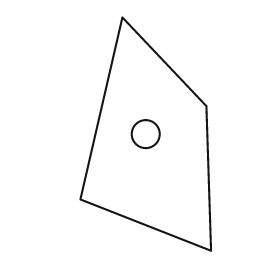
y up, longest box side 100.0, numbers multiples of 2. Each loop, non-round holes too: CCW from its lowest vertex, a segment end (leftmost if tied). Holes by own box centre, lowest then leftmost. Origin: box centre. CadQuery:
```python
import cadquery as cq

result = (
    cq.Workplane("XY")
    .moveTo(28.0, -50.0)
    .lineTo(26.0, 12.0)
    .lineTo(-10.0, 50.0)
    .lineTo(-28.0, -28.0)
    .close()
    .moveTo(0.0, 0.0)
    .circle(6.0)
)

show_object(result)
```